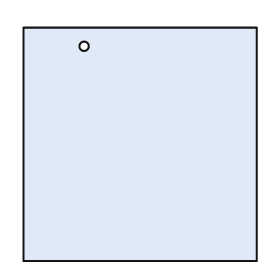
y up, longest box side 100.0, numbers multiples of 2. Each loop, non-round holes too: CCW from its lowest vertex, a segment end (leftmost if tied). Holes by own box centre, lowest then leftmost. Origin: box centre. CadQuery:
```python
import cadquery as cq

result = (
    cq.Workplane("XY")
    .moveTo(-50.0, -50.0)
    .lineTo(50.0, -50.0)
    .lineTo(50.0, 50.0)
    .lineTo(-50.0, 50.0)
    .close()
    .moveTo(-24.0, 42.0)
    .circle(2.0)
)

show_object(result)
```